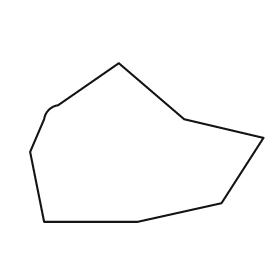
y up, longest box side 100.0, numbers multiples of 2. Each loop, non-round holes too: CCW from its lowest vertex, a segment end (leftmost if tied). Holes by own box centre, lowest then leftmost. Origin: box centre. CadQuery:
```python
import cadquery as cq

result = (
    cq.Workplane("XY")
    .moveTo(-44.0, -34.0)
    .lineTo(-4.0, -34.0)
    .lineTo(32.0, -26.0)
    .lineTo(50.0, 2.0)
    .lineTo(16.0, 10.0)
    .lineTo(-12.0, 34.0)
    .lineTo(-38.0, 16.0)
    .threePointArc((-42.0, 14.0), (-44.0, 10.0))
    .lineTo(-50.0, -4.0)
    .close()
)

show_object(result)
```